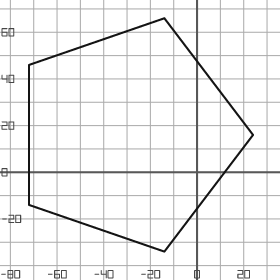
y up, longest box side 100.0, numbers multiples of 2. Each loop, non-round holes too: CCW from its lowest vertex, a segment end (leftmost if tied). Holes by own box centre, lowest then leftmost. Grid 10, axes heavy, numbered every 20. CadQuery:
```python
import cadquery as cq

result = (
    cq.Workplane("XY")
    .moveTo(-14.0, -34.0)
    .lineTo(24.0, 16.0)
    .lineTo(-14.0, 66.0)
    .lineTo(-72.0, 46.0)
    .lineTo(-72.0, -14.0)
    .close()
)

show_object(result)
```